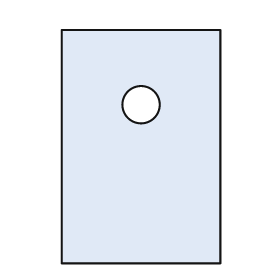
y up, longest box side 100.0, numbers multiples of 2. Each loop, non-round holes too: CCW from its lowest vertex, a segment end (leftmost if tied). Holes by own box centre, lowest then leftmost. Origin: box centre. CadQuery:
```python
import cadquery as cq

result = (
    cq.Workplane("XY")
    .moveTo(-34.0, -50.0)
    .lineTo(34.0, -50.0)
    .lineTo(34.0, 50.0)
    .lineTo(-34.0, 50.0)
    .close()
    .moveTo(0.0, 18.0)
    .circle(8.0)
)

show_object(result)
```